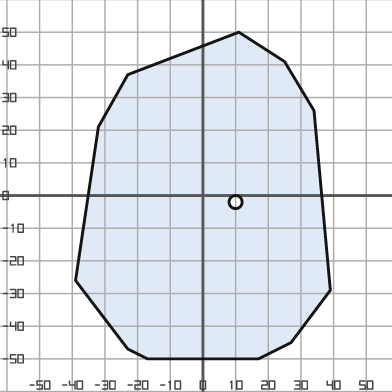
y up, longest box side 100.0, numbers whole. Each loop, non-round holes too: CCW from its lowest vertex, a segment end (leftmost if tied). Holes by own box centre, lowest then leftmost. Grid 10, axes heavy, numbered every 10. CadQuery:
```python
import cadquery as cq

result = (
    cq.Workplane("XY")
    .moveTo(-17.0, -50.0)
    .lineTo(17.0, -50.0)
    .lineTo(27.0, -45.0)
    .lineTo(39.0, -29.0)
    .lineTo(34.0, 26.0)
    .lineTo(25.0, 41.0)
    .lineTo(11.0, 50.0)
    .lineTo(-23.0, 37.0)
    .lineTo(-32.0, 21.0)
    .lineTo(-39.0, -26.0)
    .lineTo(-23.0, -47.0)
    .close()
    .moveTo(10.0, -2.0)
    .circle(2.0)
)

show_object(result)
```